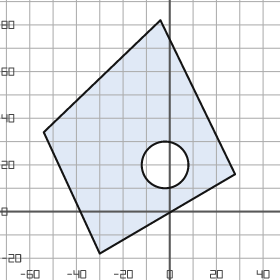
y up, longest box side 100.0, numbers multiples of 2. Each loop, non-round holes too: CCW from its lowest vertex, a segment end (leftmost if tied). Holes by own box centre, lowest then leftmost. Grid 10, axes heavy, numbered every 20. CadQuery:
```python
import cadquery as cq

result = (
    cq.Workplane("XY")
    .moveTo(-30.0, -18.0)
    .lineTo(28.0, 16.0)
    .lineTo(-4.0, 82.0)
    .lineTo(-54.0, 34.0)
    .close()
    .moveTo(-2.0, 20.0)
    .circle(10.0)
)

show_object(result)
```